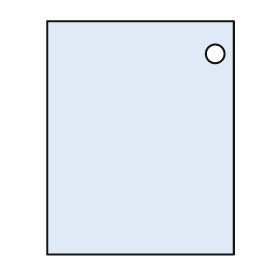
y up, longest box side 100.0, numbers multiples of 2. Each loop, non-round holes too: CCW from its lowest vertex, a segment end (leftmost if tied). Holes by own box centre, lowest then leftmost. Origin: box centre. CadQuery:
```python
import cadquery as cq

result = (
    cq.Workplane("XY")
    .moveTo(-40.0, -50.0)
    .lineTo(40.0, -50.0)
    .lineTo(40.0, 50.0)
    .lineTo(-40.0, 50.0)
    .close()
    .moveTo(32.0, 36.0)
    .circle(4.0)
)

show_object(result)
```